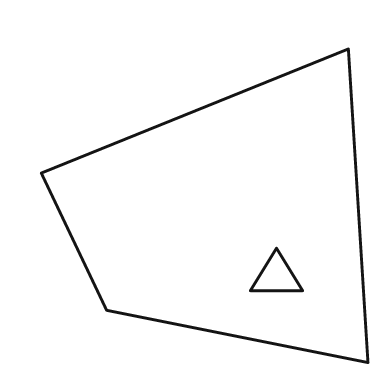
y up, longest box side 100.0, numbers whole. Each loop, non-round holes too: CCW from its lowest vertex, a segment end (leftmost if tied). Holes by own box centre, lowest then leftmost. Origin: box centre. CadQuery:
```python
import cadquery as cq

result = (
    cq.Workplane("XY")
    .moveTo(50.0, -48.0)
    .lineTo(44.0, 48.0)
    .lineTo(-50.0, 10.0)
    .lineTo(-30.0, -32.0)
    .close()
    .moveTo(14.0, -26.0)
    .lineTo(30.0, -26.0)
    .lineTo(22.0, -13.0)
    .close()
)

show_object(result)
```